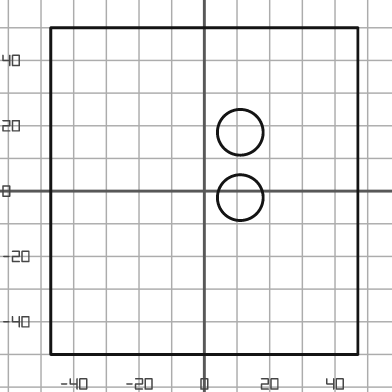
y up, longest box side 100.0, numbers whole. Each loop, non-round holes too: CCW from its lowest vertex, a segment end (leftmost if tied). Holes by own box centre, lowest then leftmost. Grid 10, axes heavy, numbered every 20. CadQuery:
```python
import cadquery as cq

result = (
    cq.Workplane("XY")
    .moveTo(-47.0, -50.0)
    .lineTo(47.0, -50.0)
    .lineTo(47.0, 50.0)
    .lineTo(-47.0, 50.0)
    .close()
    .moveTo(11.0, -2.0)
    .circle(7.0)
    .moveTo(11.0, 18.0)
    .circle(7.0)
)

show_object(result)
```